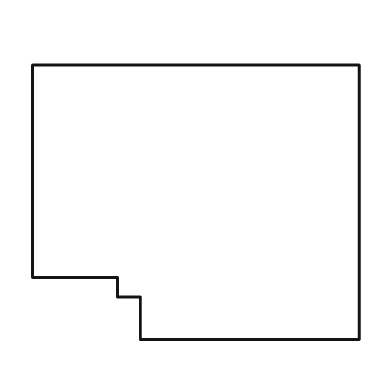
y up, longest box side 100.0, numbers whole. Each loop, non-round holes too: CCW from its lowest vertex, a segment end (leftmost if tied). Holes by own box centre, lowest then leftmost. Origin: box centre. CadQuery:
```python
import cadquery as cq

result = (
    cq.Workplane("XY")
    .moveTo(-17.0, -42.0)
    .lineTo(50.0, -42.0)
    .lineTo(50.0, 42.0)
    .lineTo(-50.0, 42.0)
    .lineTo(-50.0, -23.0)
    .lineTo(-24.0, -23.0)
    .lineTo(-24.0, -29.0)
    .lineTo(-17.0, -29.0)
    .close()
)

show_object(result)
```